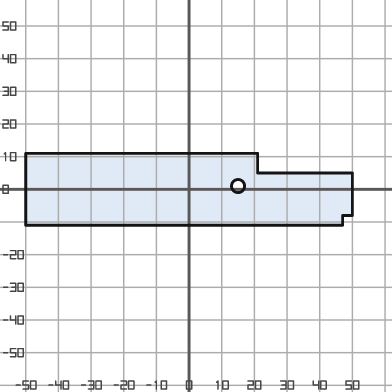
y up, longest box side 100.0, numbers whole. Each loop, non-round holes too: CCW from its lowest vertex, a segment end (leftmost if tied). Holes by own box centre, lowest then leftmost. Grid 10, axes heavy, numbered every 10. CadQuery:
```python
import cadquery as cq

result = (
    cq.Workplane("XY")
    .moveTo(-50.0, -11.0)
    .lineTo(47.0, -11.0)
    .lineTo(47.0, -8.0)
    .lineTo(50.0, -8.0)
    .lineTo(50.0, 5.0)
    .lineTo(21.0, 5.0)
    .lineTo(21.0, 11.0)
    .lineTo(-50.0, 11.0)
    .close()
    .moveTo(15.0, 1.0)
    .circle(2.0)
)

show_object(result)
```